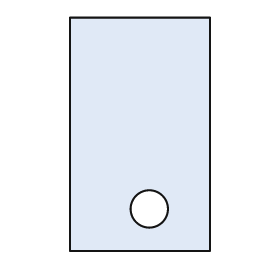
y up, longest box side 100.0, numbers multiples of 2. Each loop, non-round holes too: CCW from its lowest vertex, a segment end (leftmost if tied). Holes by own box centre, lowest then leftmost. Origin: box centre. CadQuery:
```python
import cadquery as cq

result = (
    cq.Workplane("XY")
    .moveTo(-30.0, -50.0)
    .lineTo(30.0, -50.0)
    .lineTo(30.0, 50.0)
    .lineTo(-30.0, 50.0)
    .close()
    .moveTo(4.0, -32.0)
    .circle(8.0)
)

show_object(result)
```